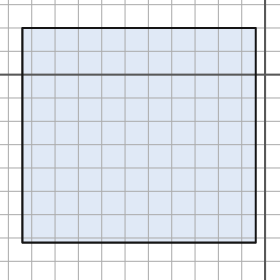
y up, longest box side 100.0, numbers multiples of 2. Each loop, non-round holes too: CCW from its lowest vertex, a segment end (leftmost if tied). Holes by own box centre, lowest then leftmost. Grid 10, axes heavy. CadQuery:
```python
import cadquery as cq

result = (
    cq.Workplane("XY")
    .moveTo(-104.0, -72.0)
    .lineTo(-4.0, -72.0)
    .lineTo(-4.0, 20.0)
    .lineTo(-104.0, 20.0)
    .close()
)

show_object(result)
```